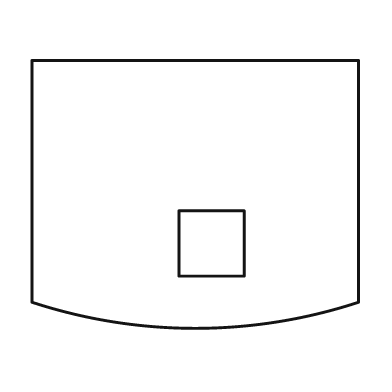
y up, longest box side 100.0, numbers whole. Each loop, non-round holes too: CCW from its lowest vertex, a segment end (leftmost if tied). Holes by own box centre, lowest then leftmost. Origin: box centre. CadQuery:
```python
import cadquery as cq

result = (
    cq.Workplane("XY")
    .moveTo(-50.0, -33.0)
    .threePointArc((0.0, -41.0), (50.0, -33.0))
    .lineTo(50.0, 41.0)
    .lineTo(-50.0, 41.0)
    .close()
    .moveTo(-5.0, -25.0)
    .lineTo(15.0, -25.0)
    .lineTo(15.0, -5.0)
    .lineTo(-5.0, -5.0)
    .close()
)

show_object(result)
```